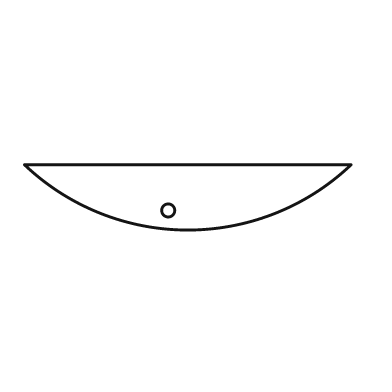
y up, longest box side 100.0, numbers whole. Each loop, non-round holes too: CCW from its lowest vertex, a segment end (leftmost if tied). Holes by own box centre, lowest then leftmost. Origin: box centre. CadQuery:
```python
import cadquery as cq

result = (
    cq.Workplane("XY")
    .moveTo(-50.0, 10.0)
    .threePointArc((0.0, -10.0), (50.0, 10.0))
    .close()
    .moveTo(-6.0, -4.0)
    .circle(2.0)
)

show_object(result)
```